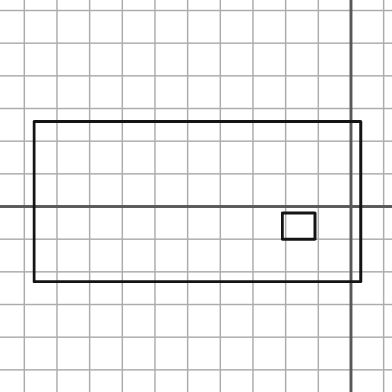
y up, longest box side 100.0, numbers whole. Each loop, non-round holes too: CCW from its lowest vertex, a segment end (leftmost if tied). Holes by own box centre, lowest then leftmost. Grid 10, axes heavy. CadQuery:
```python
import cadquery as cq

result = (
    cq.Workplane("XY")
    .moveTo(-97.0, -23.0)
    .lineTo(3.0, -23.0)
    .lineTo(3.0, 26.0)
    .lineTo(-97.0, 26.0)
    .close()
    .moveTo(-21.0, -10.0)
    .lineTo(-11.0, -10.0)
    .lineTo(-11.0, -2.0)
    .lineTo(-21.0, -2.0)
    .close()
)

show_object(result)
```